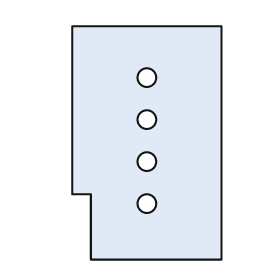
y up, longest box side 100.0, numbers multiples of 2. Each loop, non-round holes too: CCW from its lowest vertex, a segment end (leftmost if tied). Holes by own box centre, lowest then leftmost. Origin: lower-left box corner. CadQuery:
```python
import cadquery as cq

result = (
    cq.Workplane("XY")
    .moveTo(8.0, 0.0)
    .lineTo(64.0, 0.0)
    .lineTo(64.0, 100.0)
    .lineTo(0.0, 100.0)
    .lineTo(0.0, 28.0)
    .lineTo(8.0, 28.0)
    .close()
    .moveTo(32.0, 24.0)
    .circle(4.0)
    .moveTo(32.0, 42.0)
    .circle(4.0)
    .moveTo(32.0, 60.0)
    .circle(4.0)
    .moveTo(32.0, 78.0)
    .circle(4.0)
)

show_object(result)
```